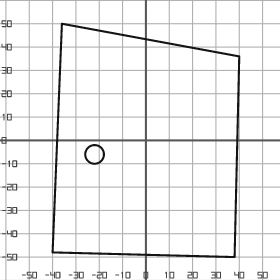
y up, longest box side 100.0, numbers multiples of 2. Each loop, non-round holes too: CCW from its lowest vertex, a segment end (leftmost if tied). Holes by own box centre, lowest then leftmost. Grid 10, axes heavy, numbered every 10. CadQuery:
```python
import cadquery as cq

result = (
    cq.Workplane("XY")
    .moveTo(38.0, -50.0)
    .lineTo(40.0, 36.0)
    .lineTo(-36.0, 50.0)
    .lineTo(-40.0, -48.0)
    .close()
    .moveTo(-22.0, -6.0)
    .circle(4.0)
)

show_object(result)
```